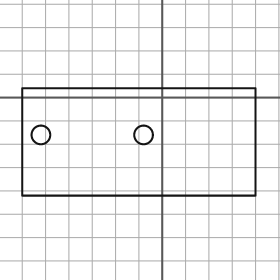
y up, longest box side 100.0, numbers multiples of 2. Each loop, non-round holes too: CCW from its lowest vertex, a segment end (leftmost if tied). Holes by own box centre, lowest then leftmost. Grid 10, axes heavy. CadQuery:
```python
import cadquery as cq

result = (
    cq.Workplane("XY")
    .moveTo(-60.0, -42.0)
    .lineTo(40.0, -42.0)
    .lineTo(40.0, 4.0)
    .lineTo(-60.0, 4.0)
    .close()
    .moveTo(-52.0, -16.0)
    .circle(4.0)
    .moveTo(-8.0, -16.0)
    .circle(4.0)
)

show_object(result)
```